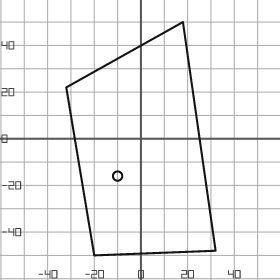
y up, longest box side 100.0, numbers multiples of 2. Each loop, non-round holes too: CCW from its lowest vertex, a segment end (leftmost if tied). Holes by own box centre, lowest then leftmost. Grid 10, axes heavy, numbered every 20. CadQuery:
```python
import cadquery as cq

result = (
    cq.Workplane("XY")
    .moveTo(-20.0, -50.0)
    .lineTo(32.0, -48.0)
    .lineTo(18.0, 50.0)
    .lineTo(-32.0, 22.0)
    .close()
    .moveTo(-10.0, -16.0)
    .circle(2.0)
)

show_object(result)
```